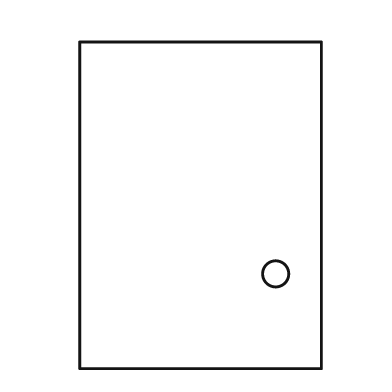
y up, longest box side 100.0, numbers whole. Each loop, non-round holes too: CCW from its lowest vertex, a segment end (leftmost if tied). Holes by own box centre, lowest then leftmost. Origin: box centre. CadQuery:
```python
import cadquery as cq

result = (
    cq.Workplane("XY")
    .moveTo(-37.0, -50.0)
    .lineTo(37.0, -50.0)
    .lineTo(37.0, 50.0)
    .lineTo(-37.0, 50.0)
    .close()
    .moveTo(23.0, -21.0)
    .circle(4.0)
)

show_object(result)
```